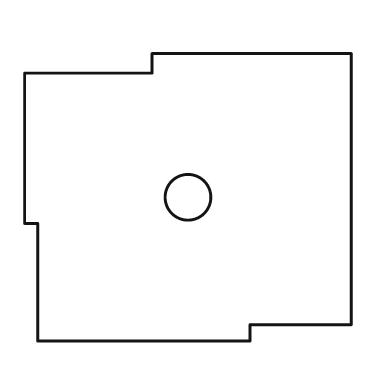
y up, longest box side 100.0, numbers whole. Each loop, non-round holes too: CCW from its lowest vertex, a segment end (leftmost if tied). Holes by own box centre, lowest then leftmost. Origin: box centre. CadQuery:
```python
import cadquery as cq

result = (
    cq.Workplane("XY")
    .moveTo(-46.0, -44.0)
    .lineTo(19.0, -44.0)
    .lineTo(19.0, -39.0)
    .lineTo(50.0, -39.0)
    .lineTo(50.0, 44.0)
    .lineTo(-11.0, 44.0)
    .lineTo(-11.0, 38.0)
    .lineTo(-50.0, 38.0)
    .lineTo(-50.0, -8.0)
    .lineTo(-46.0, -8.0)
    .close()
    .moveTo(0.0, 0.0)
    .circle(7.0)
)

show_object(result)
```